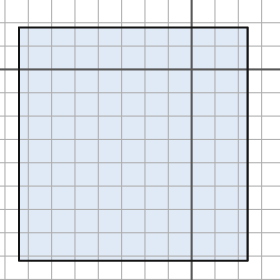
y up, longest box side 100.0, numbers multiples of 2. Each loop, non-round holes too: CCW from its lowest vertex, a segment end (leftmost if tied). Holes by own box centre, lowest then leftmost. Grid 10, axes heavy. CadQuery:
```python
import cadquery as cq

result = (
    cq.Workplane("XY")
    .moveTo(-74.0, -82.0)
    .lineTo(24.0, -82.0)
    .lineTo(24.0, 18.0)
    .lineTo(-74.0, 18.0)
    .close()
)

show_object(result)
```